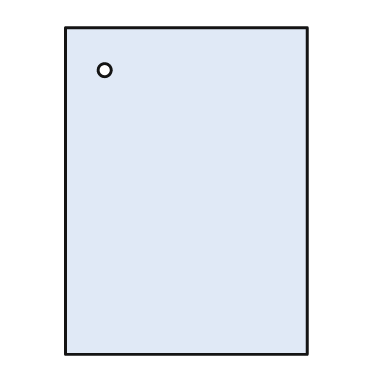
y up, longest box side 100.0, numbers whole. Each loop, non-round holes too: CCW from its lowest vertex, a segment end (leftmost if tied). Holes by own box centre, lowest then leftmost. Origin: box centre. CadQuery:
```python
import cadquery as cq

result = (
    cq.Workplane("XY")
    .moveTo(-37.0, -50.0)
    .lineTo(37.0, -50.0)
    .lineTo(37.0, 50.0)
    .lineTo(-37.0, 50.0)
    .close()
    .moveTo(-25.0, 37.0)
    .circle(2.0)
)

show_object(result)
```